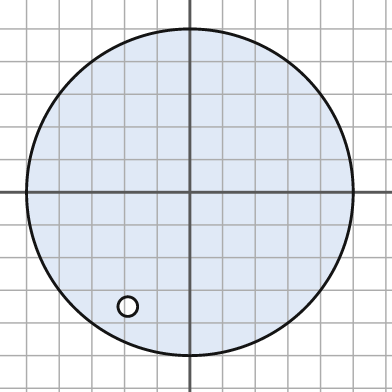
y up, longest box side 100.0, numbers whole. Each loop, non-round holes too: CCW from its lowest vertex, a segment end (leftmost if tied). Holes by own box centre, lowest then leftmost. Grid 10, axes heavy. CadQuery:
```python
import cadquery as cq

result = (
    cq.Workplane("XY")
    .moveTo(0.0, 0.0)
    .circle(50.0)
    .moveTo(-19.0, -35.0)
    .circle(3.0)
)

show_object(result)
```